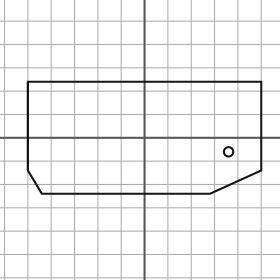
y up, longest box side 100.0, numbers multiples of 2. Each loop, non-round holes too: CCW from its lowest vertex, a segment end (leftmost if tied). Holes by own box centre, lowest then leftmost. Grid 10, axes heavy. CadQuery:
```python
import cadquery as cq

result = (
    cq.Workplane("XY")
    .moveTo(-44.0, -24.0)
    .lineTo(28.0, -24.0)
    .lineTo(50.0, -14.0)
    .lineTo(50.0, 24.0)
    .lineTo(-50.0, 24.0)
    .lineTo(-50.0, -14.0)
    .close()
    .moveTo(36.0, -6.0)
    .circle(2.0)
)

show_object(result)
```